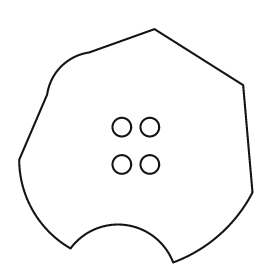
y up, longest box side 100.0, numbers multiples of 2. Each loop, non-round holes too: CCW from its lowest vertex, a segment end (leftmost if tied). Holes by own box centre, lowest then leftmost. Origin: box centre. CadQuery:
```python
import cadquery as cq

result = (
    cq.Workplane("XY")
    .moveTo(16.0, -50.0)
    .threePointArc((36.0, -38.0), (50.0, -20.0))
    .lineTo(46.0, 26.0)
    .lineTo(8.0, 50.0)
    .lineTo(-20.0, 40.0)
    .threePointArc((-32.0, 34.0), (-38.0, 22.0))
    .lineTo(-50.0, -6.0)
    .threePointArc((-44.0, -28.0), (-28.0, -44.0))
    .threePointArc((-4.0, -34.0), (16.0, -50.0))
    .close()
    .moveTo(-6.0, -8.0)
    .circle(4.0)
    .moveTo(6.0, -8.0)
    .circle(4.0)
    .moveTo(-6.0, 8.0)
    .circle(4.0)
    .moveTo(6.0, 8.0)
    .circle(4.0)
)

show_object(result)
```